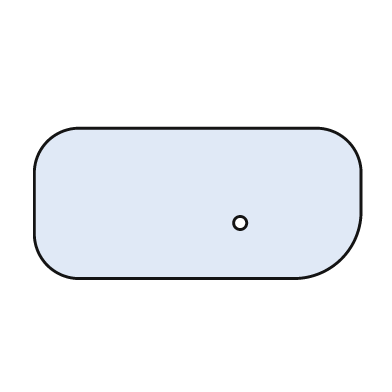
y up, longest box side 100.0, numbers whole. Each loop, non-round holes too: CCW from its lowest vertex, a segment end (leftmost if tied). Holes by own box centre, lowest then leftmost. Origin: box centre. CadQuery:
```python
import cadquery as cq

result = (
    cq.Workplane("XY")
    .moveTo(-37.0, -23.0)
    .lineTo(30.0, -23.0)
    .threePointArc((44.0, -17.0), (50.0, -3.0))
    .lineTo(50.0, 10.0)
    .threePointArc((46.0, 19.0), (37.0, 23.0))
    .lineTo(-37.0, 23.0)
    .threePointArc((-46.0, 19.0), (-50.0, 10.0))
    .lineTo(-50.0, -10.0)
    .threePointArc((-46.0, -19.0), (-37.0, -23.0))
    .close()
    .moveTo(13.0, -6.0)
    .circle(2.0)
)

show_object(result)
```